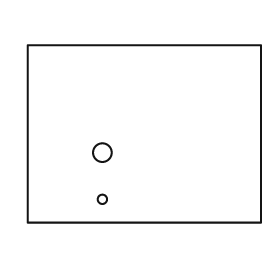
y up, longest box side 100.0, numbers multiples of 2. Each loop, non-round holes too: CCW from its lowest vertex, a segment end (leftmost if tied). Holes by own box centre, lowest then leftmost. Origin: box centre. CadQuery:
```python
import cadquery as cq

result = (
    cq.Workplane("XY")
    .moveTo(-50.0, -38.0)
    .lineTo(50.0, -38.0)
    .lineTo(50.0, 38.0)
    .lineTo(-50.0, 38.0)
    .close()
    .moveTo(-18.0, -28.0)
    .circle(2.0)
    .moveTo(-18.0, -8.0)
    .circle(4.0)
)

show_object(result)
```